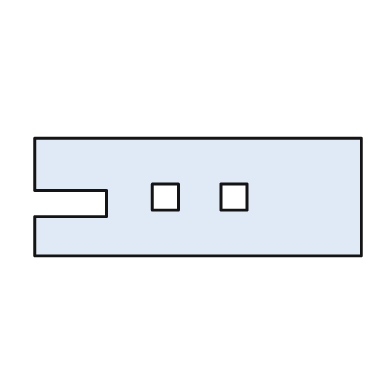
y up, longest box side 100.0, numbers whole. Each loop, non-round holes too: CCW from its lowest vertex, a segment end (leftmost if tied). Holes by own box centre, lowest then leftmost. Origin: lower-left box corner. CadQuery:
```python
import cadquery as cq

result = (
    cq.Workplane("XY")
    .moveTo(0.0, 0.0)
    .lineTo(100.0, 0.0)
    .lineTo(100.0, 36.0)
    .lineTo(0.0, 36.0)
    .lineTo(0.0, 20.0)
    .lineTo(22.0, 20.0)
    .lineTo(22.0, 12.0)
    .lineTo(0.0, 12.0)
    .close()
    .moveTo(36.0, 14.0)
    .lineTo(44.0, 14.0)
    .lineTo(44.0, 22.0)
    .lineTo(36.0, 22.0)
    .close()
    .moveTo(57.0, 14.0)
    .lineTo(65.0, 14.0)
    .lineTo(65.0, 22.0)
    .lineTo(57.0, 22.0)
    .close()
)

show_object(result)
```